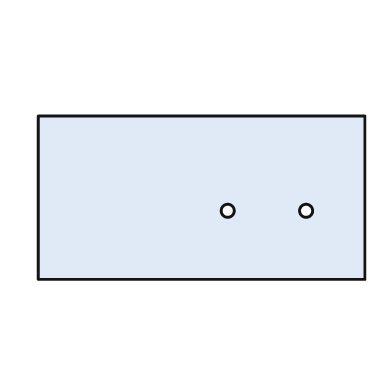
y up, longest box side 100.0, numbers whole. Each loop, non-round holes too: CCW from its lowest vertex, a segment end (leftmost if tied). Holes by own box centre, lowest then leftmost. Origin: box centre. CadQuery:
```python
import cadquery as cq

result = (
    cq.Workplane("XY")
    .moveTo(-50.0, -25.0)
    .lineTo(50.0, -25.0)
    .lineTo(50.0, 25.0)
    .lineTo(-50.0, 25.0)
    .close()
    .moveTo(8.0, -4.0)
    .circle(2.0)
    .moveTo(32.0, -4.0)
    .circle(2.0)
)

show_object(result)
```